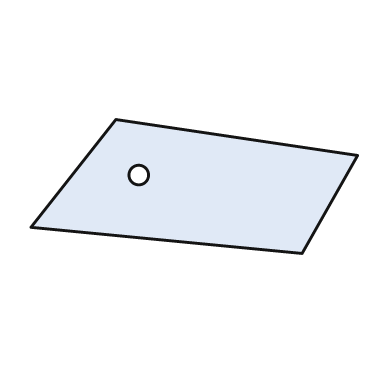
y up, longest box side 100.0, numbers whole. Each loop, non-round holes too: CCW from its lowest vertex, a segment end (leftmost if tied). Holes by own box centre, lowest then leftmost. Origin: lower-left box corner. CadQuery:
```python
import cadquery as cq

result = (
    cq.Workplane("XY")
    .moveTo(83.0, 0.0)
    .lineTo(100.0, 30.0)
    .lineTo(26.0, 41.0)
    .lineTo(0.0, 8.0)
    .close()
    .moveTo(33.0, 24.0)
    .circle(3.0)
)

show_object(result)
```